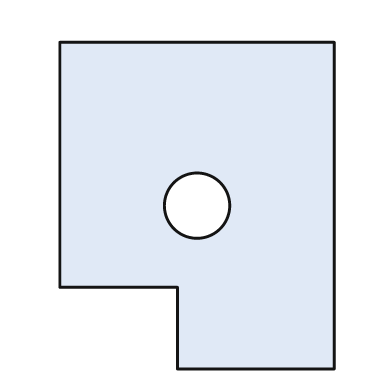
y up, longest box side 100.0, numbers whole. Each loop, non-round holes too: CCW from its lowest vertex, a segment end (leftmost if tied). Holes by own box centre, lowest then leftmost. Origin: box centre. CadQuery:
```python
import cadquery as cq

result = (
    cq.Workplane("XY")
    .moveTo(-6.0, -50.0)
    .lineTo(42.0, -50.0)
    .lineTo(42.0, 50.0)
    .lineTo(-42.0, 50.0)
    .lineTo(-42.0, -25.0)
    .lineTo(-6.0, -25.0)
    .close()
    .moveTo(0.0, 0.0)
    .circle(10.0)
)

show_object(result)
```